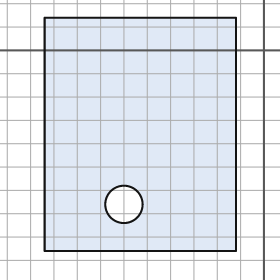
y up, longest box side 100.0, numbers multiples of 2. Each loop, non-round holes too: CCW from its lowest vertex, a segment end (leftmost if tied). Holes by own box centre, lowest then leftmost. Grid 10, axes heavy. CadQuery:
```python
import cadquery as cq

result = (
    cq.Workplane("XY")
    .moveTo(-94.0, -86.0)
    .lineTo(-12.0, -86.0)
    .lineTo(-12.0, 14.0)
    .lineTo(-94.0, 14.0)
    .close()
    .moveTo(-60.0, -66.0)
    .circle(8.0)
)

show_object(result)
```